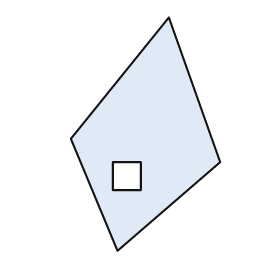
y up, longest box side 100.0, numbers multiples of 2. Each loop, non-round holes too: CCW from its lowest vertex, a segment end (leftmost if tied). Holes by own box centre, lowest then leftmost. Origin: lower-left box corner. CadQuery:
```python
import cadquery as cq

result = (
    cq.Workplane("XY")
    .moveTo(20.0, 0.0)
    .lineTo(64.0, 38.0)
    .lineTo(42.0, 100.0)
    .lineTo(0.0, 48.0)
    .close()
    .moveTo(18.0, 26.0)
    .lineTo(30.0, 26.0)
    .lineTo(30.0, 38.0)
    .lineTo(18.0, 38.0)
    .close()
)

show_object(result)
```